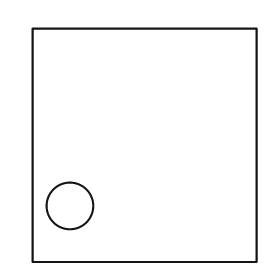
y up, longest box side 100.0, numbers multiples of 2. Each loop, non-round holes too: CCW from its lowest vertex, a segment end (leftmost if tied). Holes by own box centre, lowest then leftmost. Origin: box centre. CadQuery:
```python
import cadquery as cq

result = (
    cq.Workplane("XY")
    .moveTo(-48.0, -50.0)
    .lineTo(48.0, -50.0)
    .lineTo(48.0, 50.0)
    .lineTo(-48.0, 50.0)
    .close()
    .moveTo(-32.0, -26.0)
    .circle(10.0)
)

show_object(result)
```